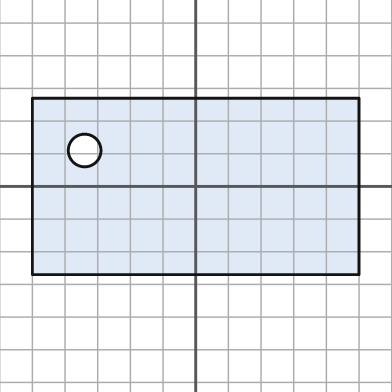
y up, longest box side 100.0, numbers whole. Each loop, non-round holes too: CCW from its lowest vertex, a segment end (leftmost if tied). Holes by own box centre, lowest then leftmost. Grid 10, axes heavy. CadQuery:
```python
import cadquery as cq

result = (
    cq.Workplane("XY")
    .moveTo(-50.0, -27.0)
    .lineTo(50.0, -27.0)
    .lineTo(50.0, 27.0)
    .lineTo(-50.0, 27.0)
    .close()
    .moveTo(-34.0, 11.0)
    .circle(5.0)
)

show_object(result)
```